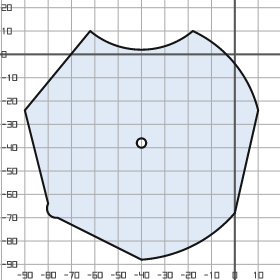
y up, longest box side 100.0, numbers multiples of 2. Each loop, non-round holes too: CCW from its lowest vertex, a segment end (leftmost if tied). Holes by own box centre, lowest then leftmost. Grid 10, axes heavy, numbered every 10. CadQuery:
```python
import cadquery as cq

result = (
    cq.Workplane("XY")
    .moveTo(-40.0, -88.0)
    .threePointArc((-18.0, -82.0), (0.0, -68.0))
    .lineTo(10.0, -24.0)
    .threePointArc((0.0, -4.0), (-18.0, 10.0))
    .threePointArc((-40.0, 2.0), (-62.0, 10.0))
    .lineTo(-90.0, -24.0)
    .lineTo(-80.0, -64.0)
    .threePointArc((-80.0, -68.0), (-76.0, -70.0))
    .close()
    .moveTo(-40.0, -38.0)
    .circle(2.0)
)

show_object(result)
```